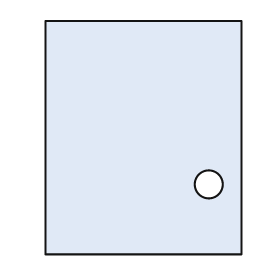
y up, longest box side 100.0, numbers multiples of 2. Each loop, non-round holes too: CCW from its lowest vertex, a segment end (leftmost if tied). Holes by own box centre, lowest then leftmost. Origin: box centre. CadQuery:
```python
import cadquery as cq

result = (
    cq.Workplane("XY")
    .moveTo(-42.0, -50.0)
    .lineTo(42.0, -50.0)
    .lineTo(42.0, 50.0)
    .lineTo(-42.0, 50.0)
    .close()
    .moveTo(28.0, -20.0)
    .circle(6.0)
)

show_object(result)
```